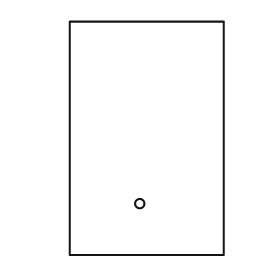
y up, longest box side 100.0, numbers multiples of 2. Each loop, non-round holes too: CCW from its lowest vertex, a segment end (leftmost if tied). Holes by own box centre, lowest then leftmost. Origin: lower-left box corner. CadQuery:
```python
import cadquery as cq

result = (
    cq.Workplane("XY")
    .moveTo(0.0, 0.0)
    .lineTo(66.0, 0.0)
    .lineTo(66.0, 100.0)
    .lineTo(0.0, 100.0)
    .close()
    .moveTo(30.0, 22.0)
    .circle(2.0)
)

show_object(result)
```